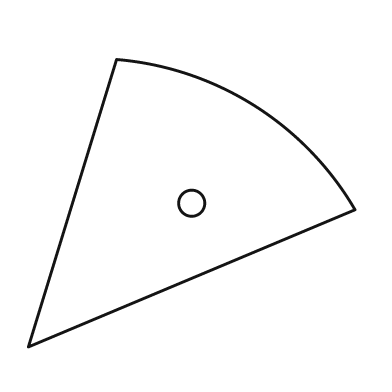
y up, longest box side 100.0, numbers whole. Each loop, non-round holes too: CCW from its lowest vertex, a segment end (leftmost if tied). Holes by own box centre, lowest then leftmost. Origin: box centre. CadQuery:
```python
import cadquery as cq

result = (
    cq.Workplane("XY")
    .moveTo(-50.0, -44.0)
    .lineTo(50.0, -2.0)
    .threePointArc((19.0, 30.0), (-23.0, 44.0))
    .close()
    .moveTo(0.0, 0.0)
    .circle(4.0)
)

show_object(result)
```